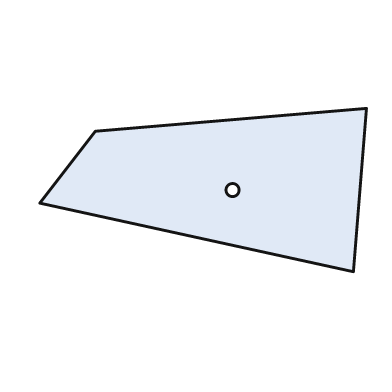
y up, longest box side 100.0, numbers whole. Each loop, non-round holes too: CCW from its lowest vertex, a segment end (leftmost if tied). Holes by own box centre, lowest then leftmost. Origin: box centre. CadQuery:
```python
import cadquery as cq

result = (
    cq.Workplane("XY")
    .moveTo(46.0, -25.0)
    .lineTo(50.0, 25.0)
    .lineTo(-33.0, 18.0)
    .lineTo(-50.0, -4.0)
    .close()
    .moveTo(9.0, 0.0)
    .circle(2.0)
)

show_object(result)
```